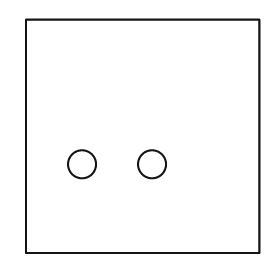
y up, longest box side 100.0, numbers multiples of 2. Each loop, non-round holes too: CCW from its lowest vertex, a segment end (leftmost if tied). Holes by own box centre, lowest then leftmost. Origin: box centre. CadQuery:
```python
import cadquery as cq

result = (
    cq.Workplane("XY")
    .moveTo(-50.0, -50.0)
    .lineTo(50.0, -50.0)
    .lineTo(50.0, 50.0)
    .lineTo(-50.0, 50.0)
    .close()
    .moveTo(-26.0, -12.0)
    .circle(6.0)
    .moveTo(4.0, -12.0)
    .circle(6.0)
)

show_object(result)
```